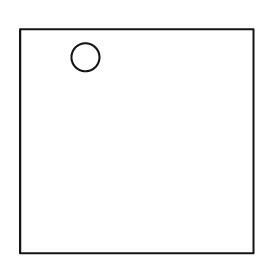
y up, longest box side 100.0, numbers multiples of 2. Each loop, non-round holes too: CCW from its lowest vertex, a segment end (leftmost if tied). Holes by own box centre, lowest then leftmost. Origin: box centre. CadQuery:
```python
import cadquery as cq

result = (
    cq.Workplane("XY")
    .moveTo(-50.0, -48.0)
    .lineTo(50.0, -48.0)
    .lineTo(50.0, 48.0)
    .lineTo(-50.0, 48.0)
    .close()
    .moveTo(-22.0, 36.0)
    .circle(6.0)
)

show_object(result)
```